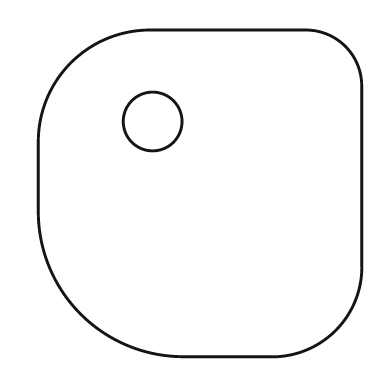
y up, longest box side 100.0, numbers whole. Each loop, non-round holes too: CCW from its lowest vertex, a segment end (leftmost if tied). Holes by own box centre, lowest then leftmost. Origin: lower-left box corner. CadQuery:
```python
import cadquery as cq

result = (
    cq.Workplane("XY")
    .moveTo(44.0, 0.0)
    .lineTo(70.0, 0.0)
    .threePointArc((91.0, 8.0), (99.0, 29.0))
    .lineTo(99.0, 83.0)
    .threePointArc((94.0, 95.0), (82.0, 100.0))
    .lineTo(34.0, 100.0)
    .threePointArc((10.0, 90.0), (0.0, 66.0))
    .lineTo(0.0, 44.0)
    .threePointArc((13.0, 13.0), (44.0, 0.0))
    .close()
    .moveTo(35.0, 72.0)
    .circle(9.0)
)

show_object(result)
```